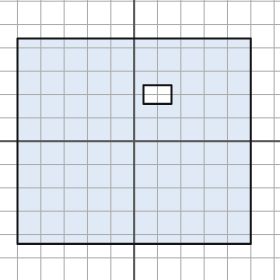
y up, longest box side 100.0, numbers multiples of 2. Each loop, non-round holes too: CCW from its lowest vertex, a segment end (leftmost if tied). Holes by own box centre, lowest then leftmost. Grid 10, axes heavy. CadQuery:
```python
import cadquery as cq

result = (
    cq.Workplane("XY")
    .moveTo(-50.0, -44.0)
    .lineTo(50.0, -44.0)
    .lineTo(50.0, 44.0)
    .lineTo(-50.0, 44.0)
    .close()
    .moveTo(4.0, 16.0)
    .lineTo(16.0, 16.0)
    .lineTo(16.0, 24.0)
    .lineTo(4.0, 24.0)
    .close()
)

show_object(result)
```